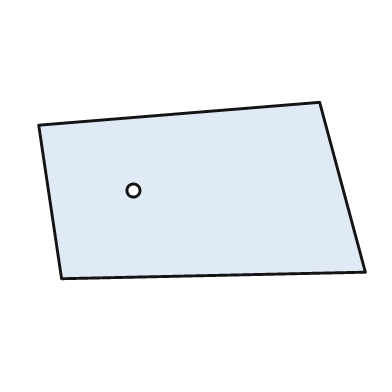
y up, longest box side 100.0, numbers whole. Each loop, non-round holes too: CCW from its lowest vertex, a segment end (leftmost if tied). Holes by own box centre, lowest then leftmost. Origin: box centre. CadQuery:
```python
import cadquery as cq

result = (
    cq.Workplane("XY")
    .moveTo(-43.0, -27.0)
    .lineTo(50.0, -25.0)
    .lineTo(36.0, 27.0)
    .lineTo(-50.0, 20.0)
    .close()
    .moveTo(-21.0, 0.0)
    .circle(2.0)
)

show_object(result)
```